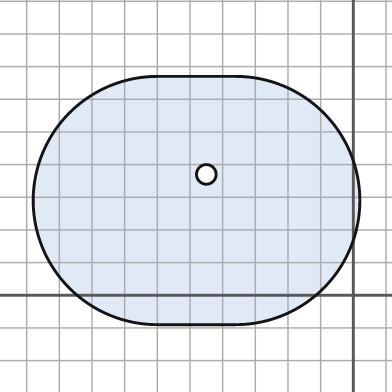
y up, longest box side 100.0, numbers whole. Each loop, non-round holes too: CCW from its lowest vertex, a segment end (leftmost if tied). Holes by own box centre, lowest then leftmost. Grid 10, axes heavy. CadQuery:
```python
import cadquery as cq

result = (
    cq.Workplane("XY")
    .moveTo(-60.0, -9.0)
    .lineTo(-36.0, -9.0)
    .threePointArc((2.0, 29.0), (-36.0, 67.0))
    .lineTo(-60.0, 67.0)
    .threePointArc((-98.0, 29.0), (-60.0, -9.0))
    .close()
    .moveTo(-45.0, 37.0)
    .circle(3.0)
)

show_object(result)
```